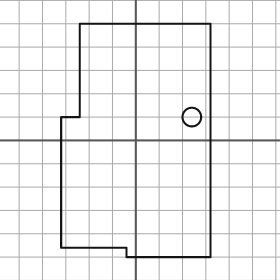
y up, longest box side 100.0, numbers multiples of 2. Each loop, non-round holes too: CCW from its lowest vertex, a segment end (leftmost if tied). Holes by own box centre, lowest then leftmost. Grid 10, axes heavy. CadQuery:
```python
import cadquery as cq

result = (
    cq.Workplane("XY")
    .moveTo(-4.0, -50.0)
    .lineTo(32.0, -50.0)
    .lineTo(32.0, 50.0)
    .lineTo(-24.0, 50.0)
    .lineTo(-24.0, 10.0)
    .lineTo(-32.0, 10.0)
    .lineTo(-32.0, -46.0)
    .lineTo(-4.0, -46.0)
    .close()
    .moveTo(24.0, 10.0)
    .circle(4.0)
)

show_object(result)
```